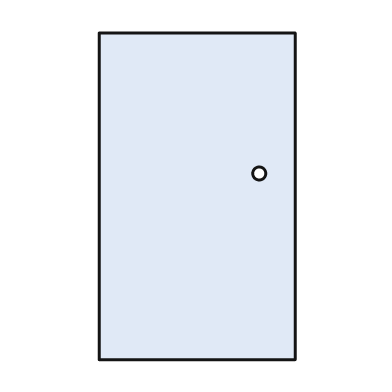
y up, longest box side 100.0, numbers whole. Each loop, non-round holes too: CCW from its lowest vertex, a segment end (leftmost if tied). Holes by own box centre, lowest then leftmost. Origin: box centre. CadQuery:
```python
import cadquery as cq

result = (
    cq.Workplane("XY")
    .moveTo(-30.0, -50.0)
    .lineTo(30.0, -50.0)
    .lineTo(30.0, 50.0)
    .lineTo(-30.0, 50.0)
    .close()
    .moveTo(19.0, 7.0)
    .circle(2.0)
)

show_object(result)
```